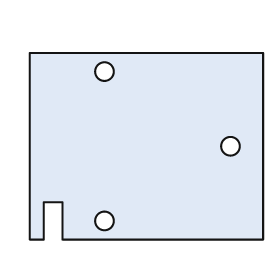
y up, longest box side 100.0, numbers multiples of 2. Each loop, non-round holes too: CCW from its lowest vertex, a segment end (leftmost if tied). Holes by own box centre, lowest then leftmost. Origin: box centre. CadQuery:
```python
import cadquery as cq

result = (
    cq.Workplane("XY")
    .moveTo(-50.0, -40.0)
    .lineTo(-44.0, -40.0)
    .lineTo(-44.0, -24.0)
    .lineTo(-36.0, -24.0)
    .lineTo(-36.0, -40.0)
    .lineTo(50.0, -40.0)
    .lineTo(50.0, 40.0)
    .lineTo(-50.0, 40.0)
    .close()
    .moveTo(-18.0, -32.0)
    .circle(4.0)
    .moveTo(36.0, 0.0)
    .circle(4.0)
    .moveTo(-18.0, 32.0)
    .circle(4.0)
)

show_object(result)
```